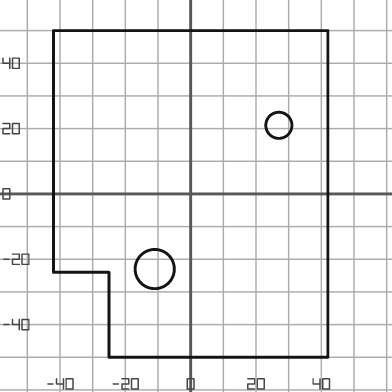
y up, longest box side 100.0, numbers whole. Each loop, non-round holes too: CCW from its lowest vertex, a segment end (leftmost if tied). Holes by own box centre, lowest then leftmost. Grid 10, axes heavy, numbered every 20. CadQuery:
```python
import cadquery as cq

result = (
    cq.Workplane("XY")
    .moveTo(-25.0, -50.0)
    .lineTo(42.0, -50.0)
    .lineTo(42.0, 50.0)
    .lineTo(-42.0, 50.0)
    .lineTo(-42.0, -24.0)
    .lineTo(-25.0, -24.0)
    .close()
    .moveTo(-11.0, -23.0)
    .circle(6.0)
    .moveTo(27.0, 21.0)
    .circle(4.0)
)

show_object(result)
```